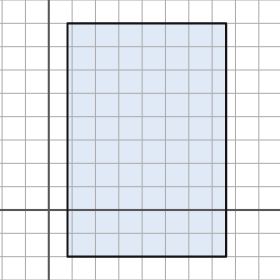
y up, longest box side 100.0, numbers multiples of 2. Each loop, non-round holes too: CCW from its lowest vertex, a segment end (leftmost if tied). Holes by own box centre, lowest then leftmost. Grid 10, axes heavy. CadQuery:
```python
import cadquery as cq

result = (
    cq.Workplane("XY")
    .moveTo(8.0, -20.0)
    .lineTo(76.0, -20.0)
    .lineTo(76.0, 80.0)
    .lineTo(8.0, 80.0)
    .close()
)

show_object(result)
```